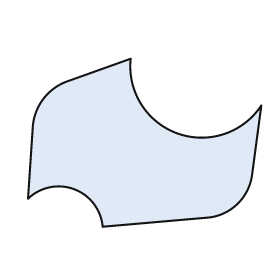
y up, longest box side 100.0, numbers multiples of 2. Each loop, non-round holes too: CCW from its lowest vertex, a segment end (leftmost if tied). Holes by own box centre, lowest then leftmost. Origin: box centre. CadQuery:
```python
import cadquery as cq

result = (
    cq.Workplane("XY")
    .moveTo(-18.0, -36.0)
    .lineTo(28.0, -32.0)
    .threePointArc((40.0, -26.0), (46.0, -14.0))
    .lineTo(50.0, 16.0)
    .threePointArc((14.0, 4.0), (-6.0, 36.0))
    .lineTo(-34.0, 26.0)
    .threePointArc((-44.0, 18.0), (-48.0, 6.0))
    .lineTo(-50.0, -24.0)
    .threePointArc((-30.0, -20.0), (-18.0, -36.0))
    .close()
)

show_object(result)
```